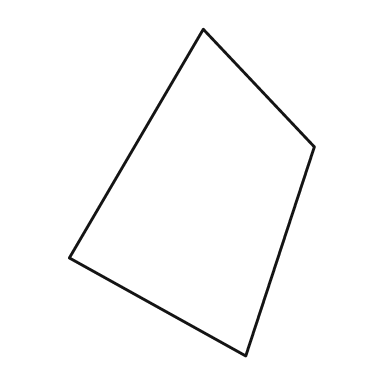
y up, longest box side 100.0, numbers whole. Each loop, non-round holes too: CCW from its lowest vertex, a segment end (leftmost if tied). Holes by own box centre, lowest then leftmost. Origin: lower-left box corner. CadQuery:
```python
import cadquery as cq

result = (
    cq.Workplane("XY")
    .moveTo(54.0, 0.0)
    .lineTo(75.0, 64.0)
    .lineTo(41.0, 100.0)
    .lineTo(0.0, 30.0)
    .close()
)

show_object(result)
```